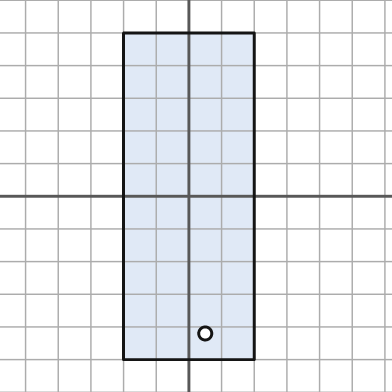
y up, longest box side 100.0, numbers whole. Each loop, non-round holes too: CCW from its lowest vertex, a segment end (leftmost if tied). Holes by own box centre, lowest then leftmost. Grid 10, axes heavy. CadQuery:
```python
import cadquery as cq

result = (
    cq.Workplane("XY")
    .moveTo(-20.0, -50.0)
    .lineTo(20.0, -50.0)
    .lineTo(20.0, 50.0)
    .lineTo(-20.0, 50.0)
    .close()
    .moveTo(5.0, -42.0)
    .circle(2.0)
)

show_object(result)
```